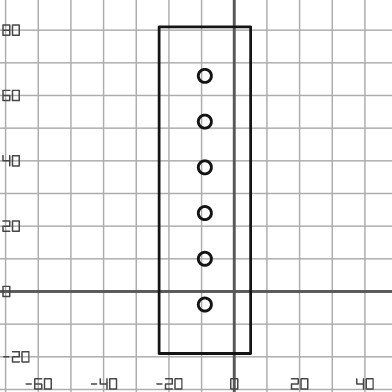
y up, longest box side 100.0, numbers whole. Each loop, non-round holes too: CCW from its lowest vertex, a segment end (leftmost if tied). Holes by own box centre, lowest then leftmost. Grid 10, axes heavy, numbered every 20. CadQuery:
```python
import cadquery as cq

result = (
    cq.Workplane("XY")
    .moveTo(-23.0, -19.0)
    .lineTo(5.0, -19.0)
    .lineTo(5.0, 81.0)
    .lineTo(-23.0, 81.0)
    .close()
    .moveTo(-9.0, -4.0)
    .circle(2.0)
    .moveTo(-9.0, 10.0)
    .circle(2.0)
    .moveTo(-9.0, 24.0)
    .circle(2.0)
    .moveTo(-9.0, 38.0)
    .circle(2.0)
    .moveTo(-9.0, 52.0)
    .circle(2.0)
    .moveTo(-9.0, 66.0)
    .circle(2.0)
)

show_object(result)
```